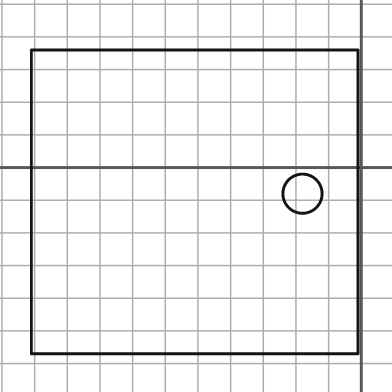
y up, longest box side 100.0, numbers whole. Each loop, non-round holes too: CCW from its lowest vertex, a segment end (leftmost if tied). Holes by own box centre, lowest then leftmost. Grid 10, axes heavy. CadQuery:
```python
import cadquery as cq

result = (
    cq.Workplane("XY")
    .moveTo(-101.0, -57.0)
    .lineTo(-1.0, -57.0)
    .lineTo(-1.0, 36.0)
    .lineTo(-101.0, 36.0)
    .close()
    .moveTo(-18.0, -8.0)
    .circle(6.0)
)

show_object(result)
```